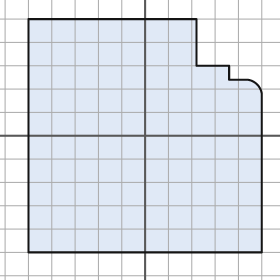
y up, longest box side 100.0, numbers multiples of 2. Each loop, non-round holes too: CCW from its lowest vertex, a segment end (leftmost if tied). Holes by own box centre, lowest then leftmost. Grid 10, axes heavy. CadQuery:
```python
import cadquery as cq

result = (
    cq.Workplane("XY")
    .moveTo(-50.0, -50.0)
    .lineTo(50.0, -50.0)
    .lineTo(50.0, 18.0)
    .threePointArc((48.0, 22.0), (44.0, 24.0))
    .lineTo(36.0, 24.0)
    .lineTo(36.0, 30.0)
    .lineTo(22.0, 30.0)
    .lineTo(22.0, 50.0)
    .lineTo(-50.0, 50.0)
    .close()
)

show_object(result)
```